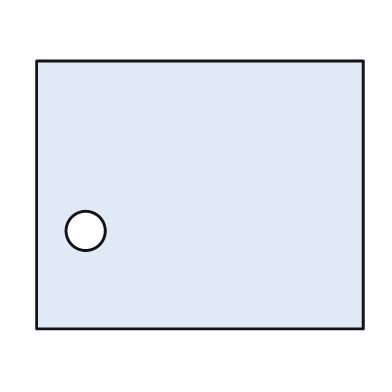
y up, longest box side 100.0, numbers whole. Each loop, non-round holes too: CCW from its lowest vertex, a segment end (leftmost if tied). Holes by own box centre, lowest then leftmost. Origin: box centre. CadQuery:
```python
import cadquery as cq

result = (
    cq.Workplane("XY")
    .moveTo(-50.0, -41.0)
    .lineTo(50.0, -41.0)
    .lineTo(50.0, 41.0)
    .lineTo(-50.0, 41.0)
    .close()
    .moveTo(-35.0, -11.0)
    .circle(6.0)
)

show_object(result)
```